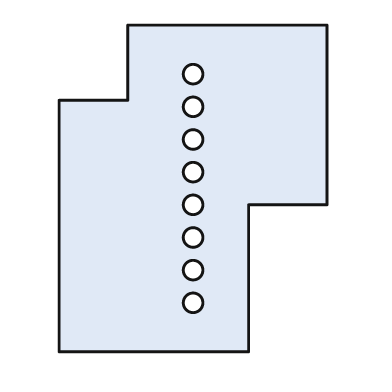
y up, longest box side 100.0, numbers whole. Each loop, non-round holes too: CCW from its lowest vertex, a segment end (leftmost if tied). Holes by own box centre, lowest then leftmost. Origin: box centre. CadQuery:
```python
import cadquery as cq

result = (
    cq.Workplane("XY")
    .moveTo(-41.0, -50.0)
    .lineTo(17.0, -50.0)
    .lineTo(17.0, -5.0)
    .lineTo(41.0, -5.0)
    .lineTo(41.0, 50.0)
    .lineTo(-20.0, 50.0)
    .lineTo(-20.0, 27.0)
    .lineTo(-41.0, 27.0)
    .close()
    .moveTo(0.0, -35.0)
    .circle(3.0)
    .moveTo(0.0, -25.0)
    .circle(3.0)
    .moveTo(0.0, -15.0)
    .circle(3.0)
    .moveTo(0.0, -5.0)
    .circle(3.0)
    .moveTo(0.0, 5.0)
    .circle(3.0)
    .moveTo(0.0, 15.0)
    .circle(3.0)
    .moveTo(0.0, 25.0)
    .circle(3.0)
    .moveTo(0.0, 35.0)
    .circle(3.0)
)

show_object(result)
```